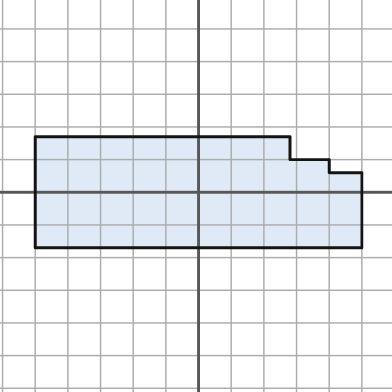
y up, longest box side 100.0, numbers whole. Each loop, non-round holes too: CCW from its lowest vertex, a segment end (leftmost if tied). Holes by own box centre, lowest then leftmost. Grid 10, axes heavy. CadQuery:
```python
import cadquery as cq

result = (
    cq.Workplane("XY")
    .moveTo(-50.0, -17.0)
    .lineTo(50.0, -17.0)
    .lineTo(50.0, 6.0)
    .lineTo(40.0, 6.0)
    .lineTo(40.0, 10.0)
    .lineTo(28.0, 10.0)
    .lineTo(28.0, 17.0)
    .lineTo(-50.0, 17.0)
    .close()
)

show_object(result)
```